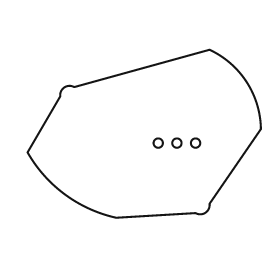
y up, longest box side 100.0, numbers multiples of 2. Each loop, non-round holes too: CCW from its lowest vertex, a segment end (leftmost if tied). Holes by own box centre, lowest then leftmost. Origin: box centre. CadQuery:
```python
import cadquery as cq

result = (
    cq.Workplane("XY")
    .moveTo(-12.0, -36.0)
    .lineTo(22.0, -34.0)
    .threePointArc((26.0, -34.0), (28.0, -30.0))
    .lineTo(50.0, 2.0)
    .threePointArc((44.0, 22.0), (28.0, 36.0))
    .lineTo(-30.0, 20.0)
    .threePointArc((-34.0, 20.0), (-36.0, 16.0))
    .lineTo(-50.0, -8.0)
    .threePointArc((-34.0, -26.0), (-12.0, -36.0))
    .close()
    .moveTo(6.0, -4.0)
    .circle(2.0)
    .moveTo(14.0, -4.0)
    .circle(2.0)
    .moveTo(22.0, -4.0)
    .circle(2.0)
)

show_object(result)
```